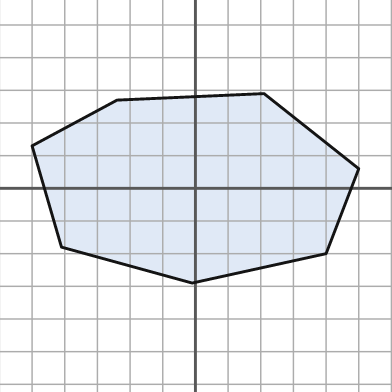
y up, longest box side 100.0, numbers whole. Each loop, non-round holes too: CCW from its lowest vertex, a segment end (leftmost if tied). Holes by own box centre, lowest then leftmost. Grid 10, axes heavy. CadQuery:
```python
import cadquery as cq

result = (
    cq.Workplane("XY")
    .moveTo(-1.0, -29.0)
    .lineTo(40.0, -20.0)
    .lineTo(50.0, 6.0)
    .lineTo(21.0, 29.0)
    .lineTo(-24.0, 27.0)
    .lineTo(-50.0, 13.0)
    .lineTo(-41.0, -18.0)
    .close()
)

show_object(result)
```